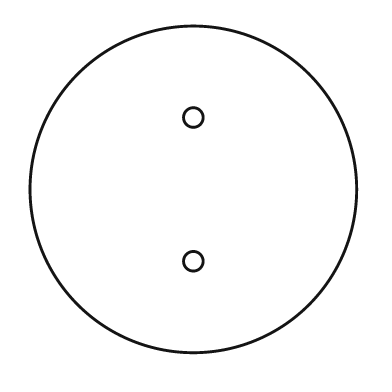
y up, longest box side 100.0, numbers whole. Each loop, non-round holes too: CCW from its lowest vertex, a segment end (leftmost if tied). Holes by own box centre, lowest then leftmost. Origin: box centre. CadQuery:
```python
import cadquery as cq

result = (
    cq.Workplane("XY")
    .moveTo(0.0, 0.0)
    .circle(50.0)
    .moveTo(0.0, -22.0)
    .circle(3.0)
    .moveTo(0.0, 22.0)
    .circle(3.0)
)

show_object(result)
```